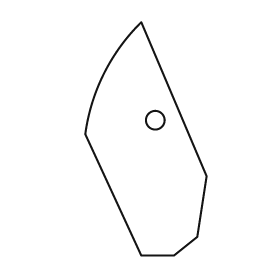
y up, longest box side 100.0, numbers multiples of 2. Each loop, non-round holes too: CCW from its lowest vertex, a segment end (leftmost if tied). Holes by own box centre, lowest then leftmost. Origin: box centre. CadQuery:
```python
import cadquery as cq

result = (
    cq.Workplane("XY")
    .moveTo(-2.0, -50.0)
    .lineTo(12.0, -50.0)
    .lineTo(22.0, -42.0)
    .lineTo(26.0, -16.0)
    .lineTo(-2.0, 50.0)
    .threePointArc((-18.0, 28.0), (-26.0, 2.0))
    .close()
    .moveTo(4.0, 8.0)
    .circle(4.0)
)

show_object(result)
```